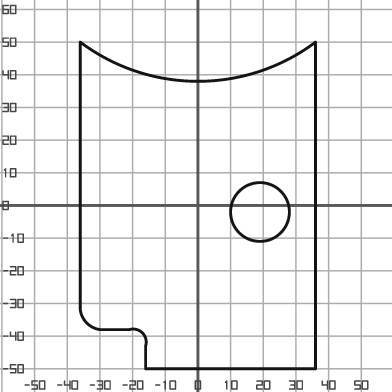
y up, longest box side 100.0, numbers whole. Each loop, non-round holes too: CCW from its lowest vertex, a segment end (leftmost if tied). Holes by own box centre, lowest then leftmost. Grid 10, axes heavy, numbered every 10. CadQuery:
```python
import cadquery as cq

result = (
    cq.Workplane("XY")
    .moveTo(-16.0, -50.0)
    .lineTo(36.0, -50.0)
    .lineTo(36.0, 50.0)
    .threePointArc((0.0, 38.0), (-36.0, 50.0))
    .lineTo(-36.0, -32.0)
    .threePointArc((-34.0, -36.0), (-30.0, -38.0))
    .lineTo(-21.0, -38.0)
    .threePointArc((-17.0, -39.0), (-16.0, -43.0))
    .close()
    .moveTo(19.0, -2.0)
    .circle(9.0)
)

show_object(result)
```